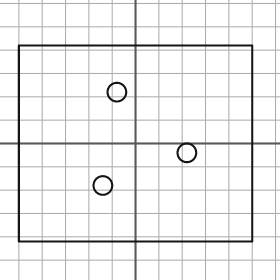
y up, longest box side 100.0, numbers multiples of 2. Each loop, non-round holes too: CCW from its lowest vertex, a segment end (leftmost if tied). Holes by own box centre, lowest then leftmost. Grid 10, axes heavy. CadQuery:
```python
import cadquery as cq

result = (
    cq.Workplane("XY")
    .moveTo(-50.0, -42.0)
    .lineTo(50.0, -42.0)
    .lineTo(50.0, 42.0)
    .lineTo(-50.0, 42.0)
    .close()
    .moveTo(-14.0, -18.0)
    .circle(4.0)
    .moveTo(22.0, -4.0)
    .circle(4.0)
    .moveTo(-8.0, 22.0)
    .circle(4.0)
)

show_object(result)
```